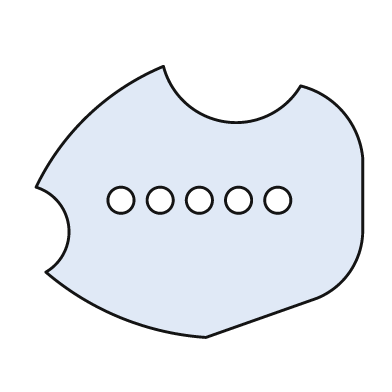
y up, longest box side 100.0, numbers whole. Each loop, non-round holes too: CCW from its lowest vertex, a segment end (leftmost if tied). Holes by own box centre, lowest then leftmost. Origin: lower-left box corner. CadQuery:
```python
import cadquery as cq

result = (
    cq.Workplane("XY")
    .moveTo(52.0, 0.0)
    .lineTo(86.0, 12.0)
    .threePointArc((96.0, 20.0), (100.0, 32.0))
    .lineTo(100.0, 55.0)
    .threePointArc((94.0, 69.0), (81.0, 77.0))
    .threePointArc((58.0, 66.0), (39.0, 83.0))
    .threePointArc((16.0, 68.0), (0.0, 46.0))
    .threePointArc((10.0, 34.0), (3.0, 20.0))
    .threePointArc((26.0, 6.0), (52.0, 0.0))
    .close()
    .moveTo(26.0, 42.0)
    .circle(4.0)
    .moveTo(38.0, 42.0)
    .circle(4.0)
    .moveTo(50.0, 42.0)
    .circle(4.0)
    .moveTo(62.0, 42.0)
    .circle(4.0)
    .moveTo(74.0, 42.0)
    .circle(4.0)
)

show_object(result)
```